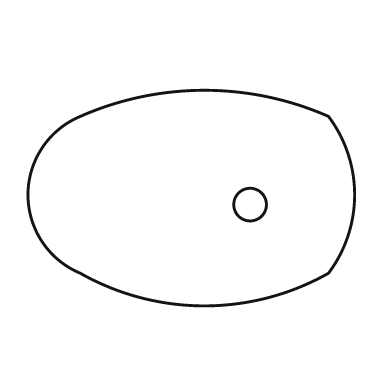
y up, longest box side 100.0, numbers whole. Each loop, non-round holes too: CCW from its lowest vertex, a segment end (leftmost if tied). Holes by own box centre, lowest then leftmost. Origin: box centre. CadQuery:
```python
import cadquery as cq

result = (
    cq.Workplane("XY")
    .moveTo(-34.0, -23.0)
    .threePointArc((4.0, -33.0), (42.0, -23.0))
    .threePointArc((50.0, 1.0), (42.0, 25.0))
    .threePointArc((4.0, 33.0), (-34.0, 25.0))
    .threePointArc((-50.0, 1.0), (-34.0, -23.0))
    .close()
    .moveTo(18.0, -2.0)
    .circle(5.0)
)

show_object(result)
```